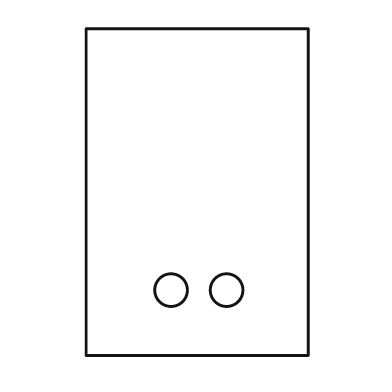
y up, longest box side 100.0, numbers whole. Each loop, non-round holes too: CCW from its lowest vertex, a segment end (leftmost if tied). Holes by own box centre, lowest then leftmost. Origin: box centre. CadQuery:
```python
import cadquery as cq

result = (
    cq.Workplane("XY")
    .moveTo(-34.0, -50.0)
    .lineTo(34.0, -50.0)
    .lineTo(34.0, 50.0)
    .lineTo(-34.0, 50.0)
    .close()
    .moveTo(-8.0, -30.0)
    .circle(5.0)
    .moveTo(9.0, -30.0)
    .circle(5.0)
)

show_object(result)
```